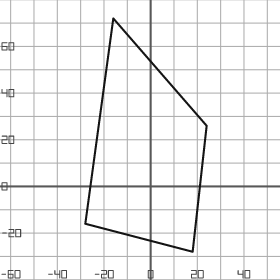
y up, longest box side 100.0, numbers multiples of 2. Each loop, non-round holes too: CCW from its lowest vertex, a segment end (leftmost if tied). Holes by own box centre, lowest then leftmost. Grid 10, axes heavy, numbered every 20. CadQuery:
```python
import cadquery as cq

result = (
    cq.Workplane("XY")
    .moveTo(18.0, -28.0)
    .lineTo(24.0, 26.0)
    .lineTo(-16.0, 72.0)
    .lineTo(-28.0, -16.0)
    .close()
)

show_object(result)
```